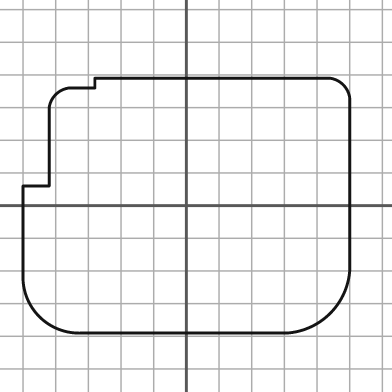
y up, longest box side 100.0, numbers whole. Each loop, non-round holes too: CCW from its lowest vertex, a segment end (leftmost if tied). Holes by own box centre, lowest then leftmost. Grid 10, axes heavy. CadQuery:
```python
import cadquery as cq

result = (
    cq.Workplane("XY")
    .moveTo(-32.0, -39.0)
    .lineTo(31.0, -39.0)
    .threePointArc((44.0, -33.0), (50.0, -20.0))
    .lineTo(50.0, 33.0)
    .threePointArc((48.0, 37.0), (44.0, 39.0))
    .lineTo(-28.0, 39.0)
    .lineTo(-28.0, 36.0)
    .lineTo(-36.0, 36.0)
    .threePointArc((-40.0, 34.0), (-42.0, 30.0))
    .lineTo(-42.0, 6.0)
    .lineTo(-50.0, 6.0)
    .lineTo(-50.0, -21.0)
    .threePointArc((-45.0, -34.0), (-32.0, -39.0))
    .close()
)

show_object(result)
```